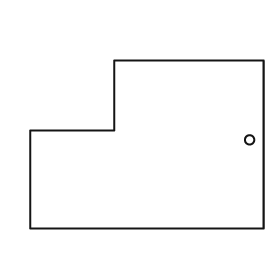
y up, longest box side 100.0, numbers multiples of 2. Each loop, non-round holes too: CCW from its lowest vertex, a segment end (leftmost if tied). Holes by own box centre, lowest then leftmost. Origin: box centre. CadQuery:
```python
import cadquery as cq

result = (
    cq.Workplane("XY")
    .moveTo(-50.0, -36.0)
    .lineTo(50.0, -36.0)
    .lineTo(50.0, 36.0)
    .lineTo(-14.0, 36.0)
    .lineTo(-14.0, 6.0)
    .lineTo(-50.0, 6.0)
    .close()
    .moveTo(44.0, 2.0)
    .circle(2.0)
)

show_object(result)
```